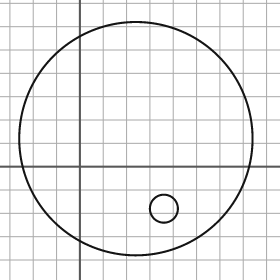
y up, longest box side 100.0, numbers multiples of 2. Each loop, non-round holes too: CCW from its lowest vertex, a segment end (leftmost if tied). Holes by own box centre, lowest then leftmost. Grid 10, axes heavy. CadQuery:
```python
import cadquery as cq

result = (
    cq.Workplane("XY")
    .moveTo(24.0, 12.0)
    .circle(50.0)
    .moveTo(36.0, -18.0)
    .circle(6.0)
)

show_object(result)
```